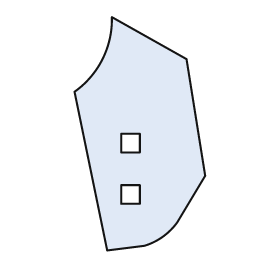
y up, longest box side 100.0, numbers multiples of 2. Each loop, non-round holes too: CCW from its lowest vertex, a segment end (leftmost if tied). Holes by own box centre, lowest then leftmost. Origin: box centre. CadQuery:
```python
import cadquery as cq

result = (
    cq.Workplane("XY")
    .moveTo(-14.0, -50.0)
    .lineTo(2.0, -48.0)
    .threePointArc((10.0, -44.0), (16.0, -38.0))
    .lineTo(28.0, -18.0)
    .lineTo(20.0, 32.0)
    .lineTo(-12.0, 50.0)
    .threePointArc((-16.0, 32.0), (-28.0, 18.0))
    .close()
    .moveTo(-8.0, -30.0)
    .lineTo(0.0, -30.0)
    .lineTo(0.0, -22.0)
    .lineTo(-8.0, -22.0)
    .close()
    .moveTo(-8.0, -8.0)
    .lineTo(0.0, -8.0)
    .lineTo(0.0, 0.0)
    .lineTo(-8.0, 0.0)
    .close()
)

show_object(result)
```